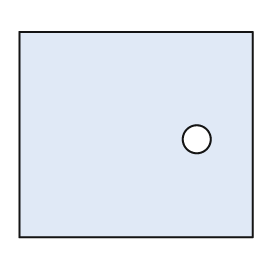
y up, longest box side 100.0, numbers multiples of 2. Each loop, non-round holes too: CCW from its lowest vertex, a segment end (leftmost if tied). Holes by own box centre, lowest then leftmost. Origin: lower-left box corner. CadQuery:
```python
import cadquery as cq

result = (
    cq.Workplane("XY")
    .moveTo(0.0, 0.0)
    .lineTo(100.0, 0.0)
    .lineTo(100.0, 88.0)
    .lineTo(0.0, 88.0)
    .close()
    .moveTo(76.0, 42.0)
    .circle(6.0)
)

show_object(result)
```